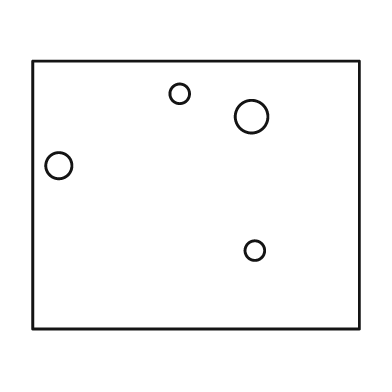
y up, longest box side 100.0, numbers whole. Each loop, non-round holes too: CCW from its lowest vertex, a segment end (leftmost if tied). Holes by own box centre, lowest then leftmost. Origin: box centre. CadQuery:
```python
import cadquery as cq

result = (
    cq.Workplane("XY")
    .moveTo(-50.0, -41.0)
    .lineTo(50.0, -41.0)
    .lineTo(50.0, 41.0)
    .lineTo(-50.0, 41.0)
    .close()
    .moveTo(18.0, -17.0)
    .circle(3.0)
    .moveTo(-42.0, 9.0)
    .circle(4.0)
    .moveTo(17.0, 24.0)
    .circle(5.0)
    .moveTo(-5.0, 31.0)
    .circle(3.0)
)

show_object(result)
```